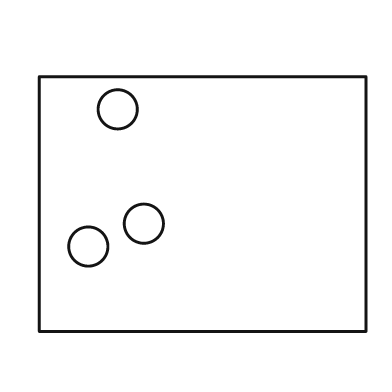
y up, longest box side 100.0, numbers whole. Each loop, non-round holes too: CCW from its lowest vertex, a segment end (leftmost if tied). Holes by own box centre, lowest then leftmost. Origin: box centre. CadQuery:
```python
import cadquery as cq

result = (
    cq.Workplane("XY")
    .moveTo(-50.0, -39.0)
    .lineTo(50.0, -39.0)
    .lineTo(50.0, 39.0)
    .lineTo(-50.0, 39.0)
    .close()
    .moveTo(-35.0, -13.0)
    .circle(6.0)
    .moveTo(-18.0, -6.0)
    .circle(6.0)
    .moveTo(-26.0, 29.0)
    .circle(6.0)
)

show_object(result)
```